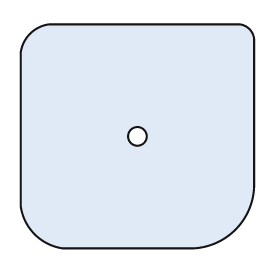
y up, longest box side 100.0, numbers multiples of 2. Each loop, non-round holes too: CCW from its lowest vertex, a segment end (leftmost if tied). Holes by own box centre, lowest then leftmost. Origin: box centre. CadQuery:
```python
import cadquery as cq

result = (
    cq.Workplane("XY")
    .moveTo(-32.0, -48.0)
    .lineTo(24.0, -48.0)
    .threePointArc((42.0, -40.0), (50.0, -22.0))
    .lineTo(50.0, 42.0)
    .threePointArc((48.0, 46.0), (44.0, 48.0))
    .lineTo(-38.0, 48.0)
    .threePointArc((-46.0, 44.0), (-50.0, 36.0))
    .lineTo(-50.0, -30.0)
    .threePointArc((-44.0, -42.0), (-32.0, -48.0))
    .close()
    .moveTo(0.0, 0.0)
    .circle(4.0)
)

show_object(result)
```